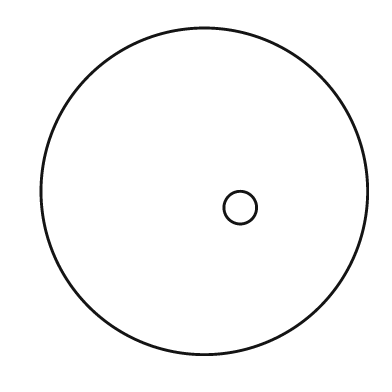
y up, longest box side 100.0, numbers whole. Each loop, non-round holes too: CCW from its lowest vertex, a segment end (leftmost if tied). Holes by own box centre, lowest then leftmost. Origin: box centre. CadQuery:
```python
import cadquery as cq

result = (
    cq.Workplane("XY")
    .moveTo(0.0, 0.0)
    .circle(50.0)
    .moveTo(11.0, -5.0)
    .circle(5.0)
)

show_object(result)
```